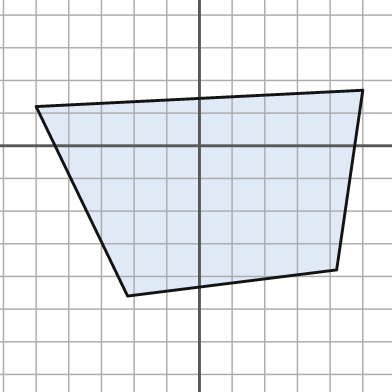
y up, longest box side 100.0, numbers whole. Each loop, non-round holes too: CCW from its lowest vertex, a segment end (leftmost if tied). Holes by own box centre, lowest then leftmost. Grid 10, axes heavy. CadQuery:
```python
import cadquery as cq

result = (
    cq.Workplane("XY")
    .moveTo(-22.0, -46.0)
    .lineTo(42.0, -38.0)
    .lineTo(50.0, 17.0)
    .lineTo(-50.0, 12.0)
    .close()
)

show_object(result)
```